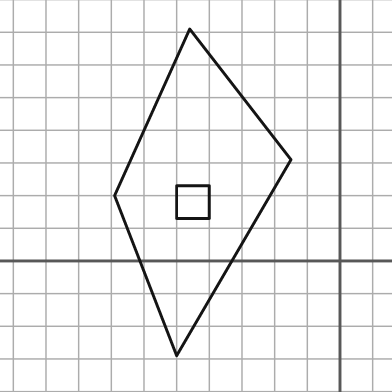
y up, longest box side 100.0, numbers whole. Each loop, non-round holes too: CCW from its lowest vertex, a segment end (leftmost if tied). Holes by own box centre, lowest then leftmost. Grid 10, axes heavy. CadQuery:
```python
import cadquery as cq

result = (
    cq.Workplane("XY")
    .moveTo(-50.0, -29.0)
    .lineTo(-15.0, 31.0)
    .lineTo(-46.0, 71.0)
    .lineTo(-69.0, 20.0)
    .close()
    .moveTo(-50.0, 13.0)
    .lineTo(-40.0, 13.0)
    .lineTo(-40.0, 23.0)
    .lineTo(-50.0, 23.0)
    .close()
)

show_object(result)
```